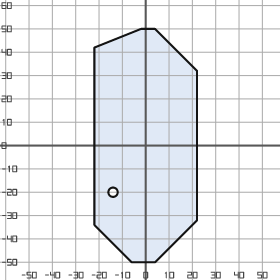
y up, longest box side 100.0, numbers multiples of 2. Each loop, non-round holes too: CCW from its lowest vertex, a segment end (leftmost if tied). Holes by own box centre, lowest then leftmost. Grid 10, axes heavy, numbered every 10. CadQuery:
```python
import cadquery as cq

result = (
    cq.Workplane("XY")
    .moveTo(-6.0, -50.0)
    .lineTo(4.0, -50.0)
    .lineTo(22.0, -32.0)
    .lineTo(22.0, 32.0)
    .lineTo(4.0, 50.0)
    .lineTo(-2.0, 50.0)
    .lineTo(-22.0, 42.0)
    .lineTo(-22.0, -34.0)
    .close()
    .moveTo(-14.0, -20.0)
    .circle(2.0)
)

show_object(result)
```